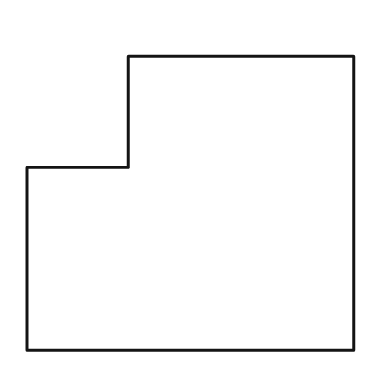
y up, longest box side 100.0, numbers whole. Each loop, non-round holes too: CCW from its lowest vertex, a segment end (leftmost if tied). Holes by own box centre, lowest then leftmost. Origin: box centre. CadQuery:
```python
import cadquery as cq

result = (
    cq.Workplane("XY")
    .moveTo(-50.0, -45.0)
    .lineTo(50.0, -45.0)
    .lineTo(50.0, 45.0)
    .lineTo(-19.0, 45.0)
    .lineTo(-19.0, 11.0)
    .lineTo(-50.0, 11.0)
    .close()
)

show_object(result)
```